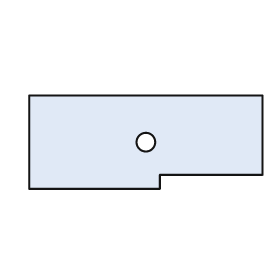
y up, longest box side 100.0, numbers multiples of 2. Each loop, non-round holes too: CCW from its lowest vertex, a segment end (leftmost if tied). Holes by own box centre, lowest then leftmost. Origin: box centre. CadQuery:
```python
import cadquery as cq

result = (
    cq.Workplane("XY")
    .moveTo(-50.0, -20.0)
    .lineTo(6.0, -20.0)
    .lineTo(6.0, -14.0)
    .lineTo(50.0, -14.0)
    .lineTo(50.0, 20.0)
    .lineTo(-50.0, 20.0)
    .close()
    .moveTo(0.0, 0.0)
    .circle(4.0)
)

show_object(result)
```